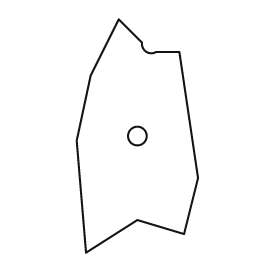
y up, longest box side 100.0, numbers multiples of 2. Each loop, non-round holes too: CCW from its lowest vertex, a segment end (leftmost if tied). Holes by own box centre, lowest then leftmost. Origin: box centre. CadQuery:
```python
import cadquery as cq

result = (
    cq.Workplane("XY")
    .moveTo(-22.0, -50.0)
    .lineTo(0.0, -36.0)
    .lineTo(20.0, -42.0)
    .lineTo(26.0, -18.0)
    .lineTo(18.0, 36.0)
    .lineTo(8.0, 36.0)
    .threePointArc((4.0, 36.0), (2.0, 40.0))
    .lineTo(-8.0, 50.0)
    .lineTo(-20.0, 26.0)
    .lineTo(-26.0, -2.0)
    .close()
    .moveTo(0.0, 0.0)
    .circle(4.0)
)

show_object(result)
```